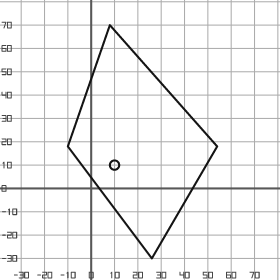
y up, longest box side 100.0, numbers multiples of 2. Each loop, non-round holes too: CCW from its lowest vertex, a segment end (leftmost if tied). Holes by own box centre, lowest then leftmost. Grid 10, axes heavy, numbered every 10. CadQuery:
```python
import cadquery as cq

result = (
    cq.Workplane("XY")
    .moveTo(26.0, -30.0)
    .lineTo(54.0, 18.0)
    .lineTo(8.0, 70.0)
    .lineTo(-10.0, 18.0)
    .close()
    .moveTo(10.0, 10.0)
    .circle(2.0)
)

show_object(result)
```